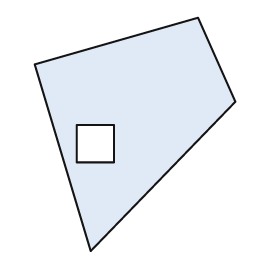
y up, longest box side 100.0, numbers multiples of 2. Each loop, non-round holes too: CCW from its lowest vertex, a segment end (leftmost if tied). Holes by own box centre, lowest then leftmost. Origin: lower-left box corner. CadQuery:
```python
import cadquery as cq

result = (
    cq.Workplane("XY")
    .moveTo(24.0, 0.0)
    .lineTo(86.0, 64.0)
    .lineTo(70.0, 100.0)
    .lineTo(0.0, 80.0)
    .close()
    .moveTo(18.0, 38.0)
    .lineTo(34.0, 38.0)
    .lineTo(34.0, 54.0)
    .lineTo(18.0, 54.0)
    .close()
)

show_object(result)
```